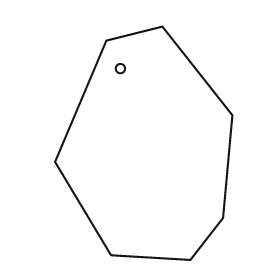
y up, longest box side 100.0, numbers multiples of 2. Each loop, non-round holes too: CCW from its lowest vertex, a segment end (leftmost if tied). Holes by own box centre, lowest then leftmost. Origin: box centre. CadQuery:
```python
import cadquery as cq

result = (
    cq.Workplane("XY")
    .moveTo(20.0, -50.0)
    .lineTo(34.0, -32.0)
    .lineTo(38.0, 12.0)
    .lineTo(8.0, 50.0)
    .lineTo(-16.0, 44.0)
    .lineTo(-38.0, -8.0)
    .lineTo(-14.0, -48.0)
    .close()
    .moveTo(-10.0, 32.0)
    .circle(2.0)
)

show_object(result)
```